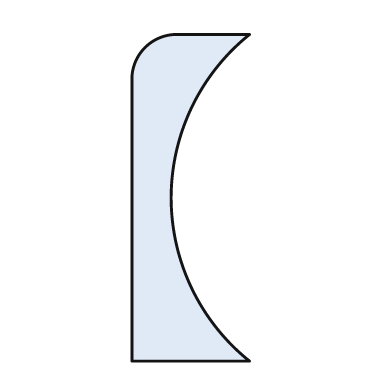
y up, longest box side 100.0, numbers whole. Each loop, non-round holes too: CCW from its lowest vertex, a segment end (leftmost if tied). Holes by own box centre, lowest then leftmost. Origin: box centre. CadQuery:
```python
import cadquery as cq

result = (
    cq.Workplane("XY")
    .moveTo(-18.0, -50.0)
    .lineTo(18.0, -50.0)
    .threePointArc((-6.0, 0.0), (18.0, 50.0))
    .lineTo(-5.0, 50.0)
    .threePointArc((-14.0, 46.0), (-18.0, 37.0))
    .close()
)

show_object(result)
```